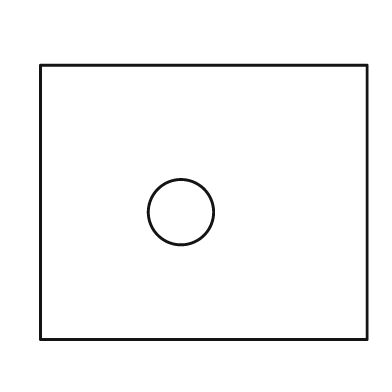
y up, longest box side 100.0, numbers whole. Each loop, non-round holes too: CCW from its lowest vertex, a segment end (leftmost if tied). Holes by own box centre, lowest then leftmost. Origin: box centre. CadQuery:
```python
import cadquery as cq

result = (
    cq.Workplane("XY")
    .moveTo(-50.0, -42.0)
    .lineTo(50.0, -42.0)
    .lineTo(50.0, 42.0)
    .lineTo(-50.0, 42.0)
    .close()
    .moveTo(-7.0, -3.0)
    .circle(10.0)
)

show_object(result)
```